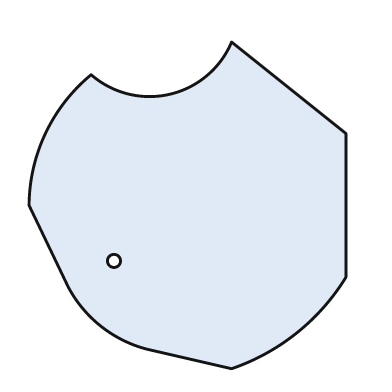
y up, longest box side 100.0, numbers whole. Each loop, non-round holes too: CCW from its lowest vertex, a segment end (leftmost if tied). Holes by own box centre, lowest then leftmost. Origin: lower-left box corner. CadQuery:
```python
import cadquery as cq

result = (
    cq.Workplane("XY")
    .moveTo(62.0, 0.0)
    .threePointArc((82.0, 11.0), (97.0, 28.0))
    .lineTo(97.0, 72.0)
    .lineTo(62.0, 100.0)
    .threePointArc((43.0, 84.0), (19.0, 90.0))
    .threePointArc((5.0, 72.0), (0.0, 50.0))
    .lineTo(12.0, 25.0)
    .threePointArc((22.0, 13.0), (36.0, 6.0))
    .close()
    .moveTo(26.0, 33.0)
    .circle(2.0)
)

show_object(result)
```